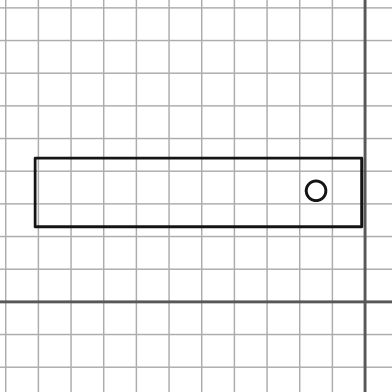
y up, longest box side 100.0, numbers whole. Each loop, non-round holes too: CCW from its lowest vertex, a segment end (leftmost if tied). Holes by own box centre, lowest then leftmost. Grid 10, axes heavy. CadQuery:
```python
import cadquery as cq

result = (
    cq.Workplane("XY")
    .moveTo(-101.0, 23.0)
    .lineTo(-1.0, 23.0)
    .lineTo(-1.0, 44.0)
    .lineTo(-101.0, 44.0)
    .close()
    .moveTo(-15.0, 34.0)
    .circle(3.0)
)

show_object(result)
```